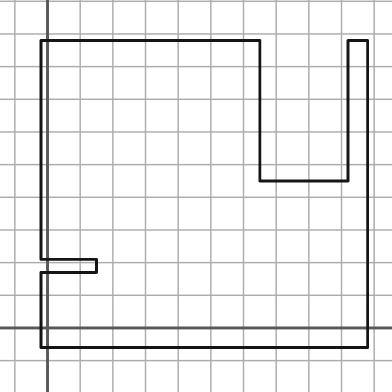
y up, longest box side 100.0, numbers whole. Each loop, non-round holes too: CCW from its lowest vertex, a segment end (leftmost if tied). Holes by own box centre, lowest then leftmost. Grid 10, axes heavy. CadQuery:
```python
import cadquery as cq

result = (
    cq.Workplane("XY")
    .moveTo(-2.0, -6.0)
    .lineTo(98.0, -6.0)
    .lineTo(98.0, 88.0)
    .lineTo(92.0, 88.0)
    .lineTo(92.0, 45.0)
    .lineTo(65.0, 45.0)
    .lineTo(65.0, 88.0)
    .lineTo(-2.0, 88.0)
    .lineTo(-2.0, 21.0)
    .lineTo(15.0, 21.0)
    .lineTo(15.0, 17.0)
    .lineTo(-2.0, 17.0)
    .close()
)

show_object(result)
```